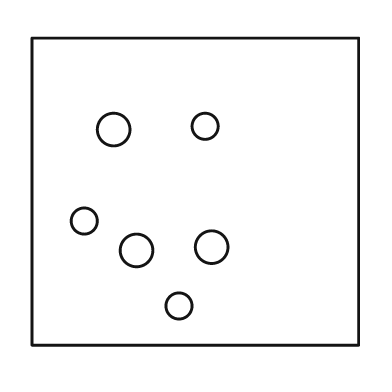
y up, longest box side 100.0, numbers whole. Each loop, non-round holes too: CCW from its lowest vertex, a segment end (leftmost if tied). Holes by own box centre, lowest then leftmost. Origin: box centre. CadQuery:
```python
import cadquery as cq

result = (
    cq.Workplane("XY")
    .moveTo(-50.0, -47.0)
    .lineTo(50.0, -47.0)
    .lineTo(50.0, 47.0)
    .lineTo(-50.0, 47.0)
    .close()
    .moveTo(-5.0, -35.0)
    .circle(4.0)
    .moveTo(-18.0, -18.0)
    .circle(5.0)
    .moveTo(5.0, -17.0)
    .circle(5.0)
    .moveTo(-34.0, -9.0)
    .circle(4.0)
    .moveTo(-25.0, 19.0)
    .circle(5.0)
    .moveTo(3.0, 20.0)
    .circle(4.0)
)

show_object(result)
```